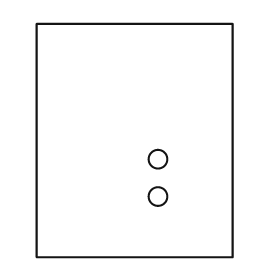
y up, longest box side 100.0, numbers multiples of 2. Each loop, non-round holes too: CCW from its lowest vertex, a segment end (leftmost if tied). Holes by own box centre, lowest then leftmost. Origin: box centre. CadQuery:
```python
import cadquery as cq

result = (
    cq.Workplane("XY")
    .moveTo(-42.0, -50.0)
    .lineTo(42.0, -50.0)
    .lineTo(42.0, 50.0)
    .lineTo(-42.0, 50.0)
    .close()
    .moveTo(10.0, -24.0)
    .circle(4.0)
    .moveTo(10.0, -8.0)
    .circle(4.0)
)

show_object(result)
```